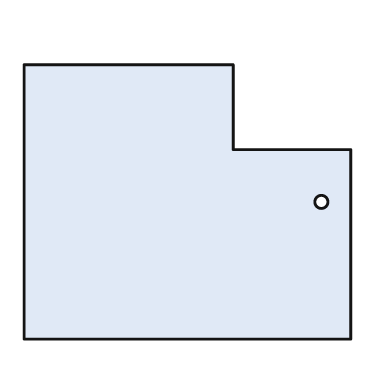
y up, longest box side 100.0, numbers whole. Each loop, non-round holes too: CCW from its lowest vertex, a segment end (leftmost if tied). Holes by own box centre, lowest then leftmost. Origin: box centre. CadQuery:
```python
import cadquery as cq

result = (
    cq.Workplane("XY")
    .moveTo(-50.0, -42.0)
    .lineTo(50.0, -42.0)
    .lineTo(50.0, 16.0)
    .lineTo(14.0, 16.0)
    .lineTo(14.0, 42.0)
    .lineTo(-50.0, 42.0)
    .close()
    .moveTo(41.0, 0.0)
    .circle(2.0)
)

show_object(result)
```